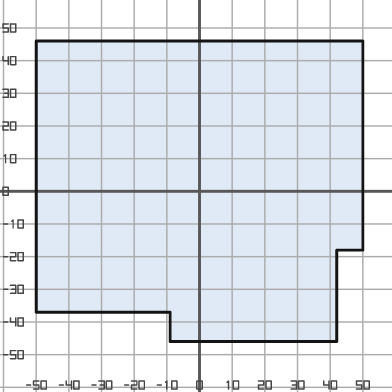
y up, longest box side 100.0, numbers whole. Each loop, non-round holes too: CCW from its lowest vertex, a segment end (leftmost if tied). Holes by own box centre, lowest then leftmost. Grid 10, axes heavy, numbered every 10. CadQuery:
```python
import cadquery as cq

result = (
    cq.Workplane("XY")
    .moveTo(-9.0, -46.0)
    .lineTo(42.0, -46.0)
    .lineTo(42.0, -18.0)
    .lineTo(50.0, -18.0)
    .lineTo(50.0, 46.0)
    .lineTo(-50.0, 46.0)
    .lineTo(-50.0, -37.0)
    .lineTo(-9.0, -37.0)
    .close()
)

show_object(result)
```